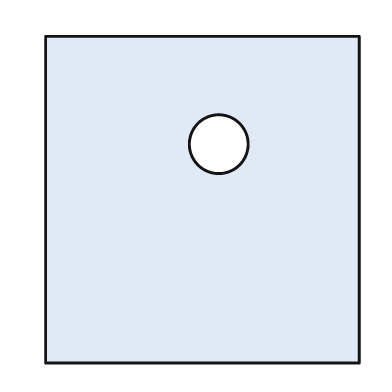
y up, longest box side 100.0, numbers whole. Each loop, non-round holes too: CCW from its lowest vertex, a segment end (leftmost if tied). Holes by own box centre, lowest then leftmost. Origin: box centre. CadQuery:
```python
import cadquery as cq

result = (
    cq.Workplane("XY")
    .moveTo(-48.0, -50.0)
    .lineTo(48.0, -50.0)
    .lineTo(48.0, 50.0)
    .lineTo(-48.0, 50.0)
    .close()
    .moveTo(5.0, 17.0)
    .circle(9.0)
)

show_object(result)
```